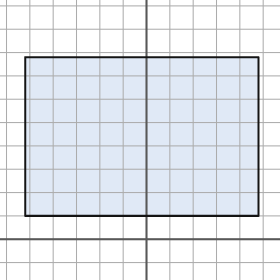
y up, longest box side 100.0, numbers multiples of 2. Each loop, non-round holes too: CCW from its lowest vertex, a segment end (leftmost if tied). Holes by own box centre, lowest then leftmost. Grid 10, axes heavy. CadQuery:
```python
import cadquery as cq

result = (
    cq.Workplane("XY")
    .moveTo(-52.0, 10.0)
    .lineTo(48.0, 10.0)
    .lineTo(48.0, 78.0)
    .lineTo(-52.0, 78.0)
    .close()
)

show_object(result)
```